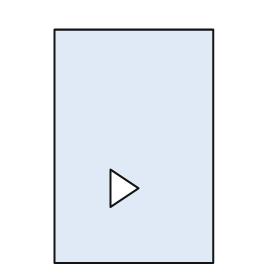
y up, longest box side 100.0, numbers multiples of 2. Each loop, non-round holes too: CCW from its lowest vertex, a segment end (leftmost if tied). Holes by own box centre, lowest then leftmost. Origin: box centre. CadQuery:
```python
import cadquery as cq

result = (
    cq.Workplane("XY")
    .moveTo(-34.0, -50.0)
    .lineTo(34.0, -50.0)
    .lineTo(34.0, 50.0)
    .lineTo(-34.0, 50.0)
    .close()
    .moveTo(-10.0, -26.0)
    .lineTo(2.0, -18.0)
    .lineTo(-10.0, -10.0)
    .close()
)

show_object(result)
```